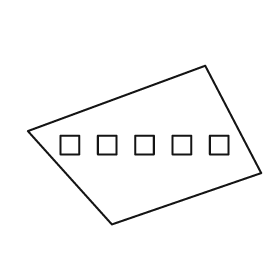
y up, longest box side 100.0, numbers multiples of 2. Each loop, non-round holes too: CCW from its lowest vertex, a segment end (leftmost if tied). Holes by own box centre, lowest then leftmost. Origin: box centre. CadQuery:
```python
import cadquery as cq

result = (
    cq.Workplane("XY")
    .moveTo(-14.0, -34.0)
    .lineTo(50.0, -12.0)
    .lineTo(26.0, 34.0)
    .lineTo(-50.0, 6.0)
    .close()
    .moveTo(-36.0, -4.0)
    .lineTo(-28.0, -4.0)
    .lineTo(-28.0, 4.0)
    .lineTo(-36.0, 4.0)
    .close()
    .moveTo(-20.0, -4.0)
    .lineTo(-12.0, -4.0)
    .lineTo(-12.0, 4.0)
    .lineTo(-20.0, 4.0)
    .close()
    .moveTo(-4.0, -4.0)
    .lineTo(4.0, -4.0)
    .lineTo(4.0, 4.0)
    .lineTo(-4.0, 4.0)
    .close()
    .moveTo(12.0, -4.0)
    .lineTo(20.0, -4.0)
    .lineTo(20.0, 4.0)
    .lineTo(12.0, 4.0)
    .close()
    .moveTo(28.0, -4.0)
    .lineTo(36.0, -4.0)
    .lineTo(36.0, 4.0)
    .lineTo(28.0, 4.0)
    .close()
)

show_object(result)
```